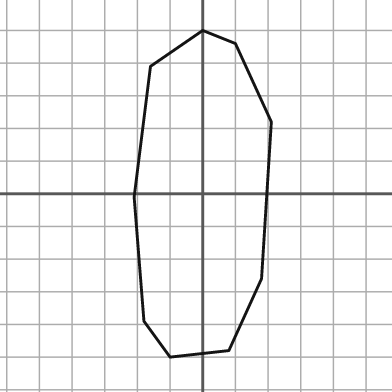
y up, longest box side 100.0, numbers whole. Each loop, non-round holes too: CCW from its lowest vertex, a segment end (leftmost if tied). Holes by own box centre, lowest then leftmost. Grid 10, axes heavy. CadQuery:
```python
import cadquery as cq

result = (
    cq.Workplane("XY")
    .moveTo(-10.0, -50.0)
    .lineTo(8.0, -48.0)
    .lineTo(18.0, -26.0)
    .lineTo(21.0, 22.0)
    .lineTo(10.0, 46.0)
    .lineTo(0.0, 50.0)
    .lineTo(-16.0, 39.0)
    .lineTo(-21.0, -1.0)
    .lineTo(-18.0, -39.0)
    .close()
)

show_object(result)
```